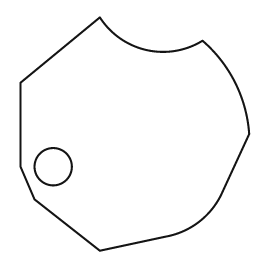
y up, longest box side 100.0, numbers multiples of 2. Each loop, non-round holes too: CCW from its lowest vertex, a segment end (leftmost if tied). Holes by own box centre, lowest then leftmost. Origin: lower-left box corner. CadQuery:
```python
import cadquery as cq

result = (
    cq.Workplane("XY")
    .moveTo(34.0, 0.0)
    .lineTo(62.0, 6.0)
    .threePointArc((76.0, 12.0), (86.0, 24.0))
    .lineTo(98.0, 50.0)
    .threePointArc((92.0, 72.0), (78.0, 90.0))
    .threePointArc((54.0, 86.0), (34.0, 100.0))
    .lineTo(0.0, 72.0)
    .lineTo(0.0, 36.0)
    .lineTo(6.0, 22.0)
    .close()
    .moveTo(14.0, 36.0)
    .circle(8.0)
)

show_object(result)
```